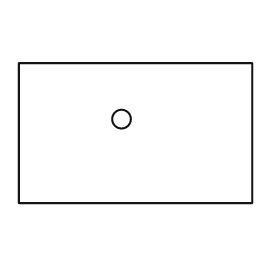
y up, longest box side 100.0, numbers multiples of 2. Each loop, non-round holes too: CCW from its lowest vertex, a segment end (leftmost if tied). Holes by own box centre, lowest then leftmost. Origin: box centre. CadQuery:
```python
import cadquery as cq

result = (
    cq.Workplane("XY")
    .moveTo(-50.0, -30.0)
    .lineTo(50.0, -30.0)
    .lineTo(50.0, 30.0)
    .lineTo(-50.0, 30.0)
    .close()
    .moveTo(-6.0, 6.0)
    .circle(4.0)
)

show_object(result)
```